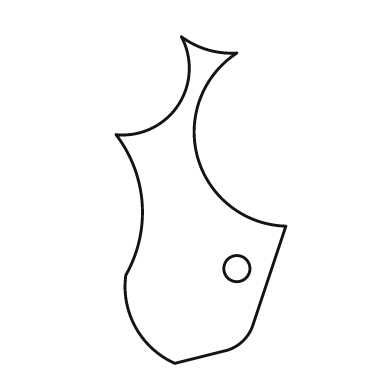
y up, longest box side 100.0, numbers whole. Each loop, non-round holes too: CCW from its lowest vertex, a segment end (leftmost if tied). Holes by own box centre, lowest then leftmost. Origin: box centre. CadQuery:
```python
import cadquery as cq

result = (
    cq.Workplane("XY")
    .moveTo(-8.0, -50.0)
    .lineTo(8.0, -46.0)
    .threePointArc((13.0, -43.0), (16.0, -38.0))
    .lineTo(26.0, -8.0)
    .threePointArc((-1.0, 13.0), (11.0, 45.0))
    .threePointArc((2.0, 46.0), (-6.0, 50.0))
    .threePointArc((-7.0, 29.0), (-26.0, 20.0))
    .threePointArc((-18.0, -1.0), (-23.0, -23.0))
    .threePointArc((-20.0, -39.0), (-8.0, -50.0))
    .close()
    .moveTo(11.0, -21.0)
    .circle(4.0)
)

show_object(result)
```